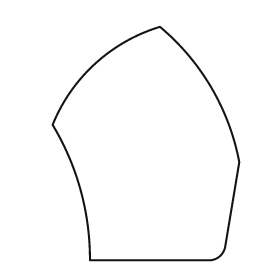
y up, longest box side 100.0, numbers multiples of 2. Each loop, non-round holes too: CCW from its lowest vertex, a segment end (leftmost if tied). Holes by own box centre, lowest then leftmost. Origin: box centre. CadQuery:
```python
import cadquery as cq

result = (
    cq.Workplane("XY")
    .moveTo(-24.0, -50.0)
    .lineTo(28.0, -50.0)
    .threePointArc((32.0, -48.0), (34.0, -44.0))
    .lineTo(40.0, -8.0)
    .threePointArc((28.0, 24.0), (6.0, 50.0))
    .threePointArc((-22.0, 34.0), (-40.0, 8.0))
    .threePointArc((-28.0, -20.0), (-24.0, -50.0))
    .close()
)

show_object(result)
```